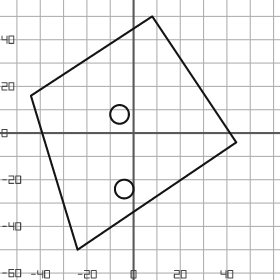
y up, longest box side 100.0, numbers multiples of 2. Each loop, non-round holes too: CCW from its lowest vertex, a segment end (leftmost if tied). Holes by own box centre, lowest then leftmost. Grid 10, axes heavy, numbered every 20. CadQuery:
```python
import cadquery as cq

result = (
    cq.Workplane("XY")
    .moveTo(-24.0, -50.0)
    .lineTo(44.0, -4.0)
    .lineTo(8.0, 50.0)
    .lineTo(-44.0, 16.0)
    .close()
    .moveTo(-4.0, -24.0)
    .circle(4.0)
    .moveTo(-6.0, 8.0)
    .circle(4.0)
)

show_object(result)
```